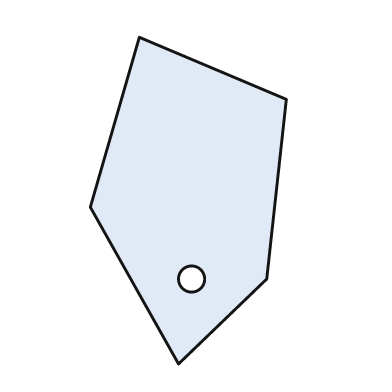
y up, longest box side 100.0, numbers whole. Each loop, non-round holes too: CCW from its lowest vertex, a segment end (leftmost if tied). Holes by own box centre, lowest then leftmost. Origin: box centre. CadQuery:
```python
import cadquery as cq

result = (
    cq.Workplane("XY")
    .moveTo(-3.0, -50.0)
    .lineTo(24.0, -24.0)
    .lineTo(30.0, 31.0)
    .lineTo(-15.0, 50.0)
    .lineTo(-30.0, -2.0)
    .close()
    .moveTo(1.0, -24.0)
    .circle(4.0)
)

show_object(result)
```